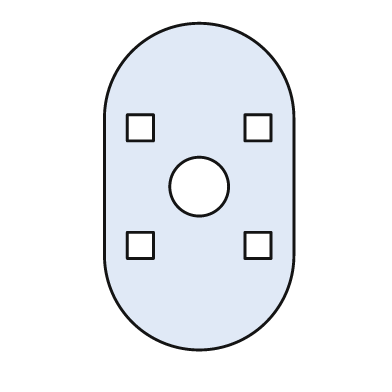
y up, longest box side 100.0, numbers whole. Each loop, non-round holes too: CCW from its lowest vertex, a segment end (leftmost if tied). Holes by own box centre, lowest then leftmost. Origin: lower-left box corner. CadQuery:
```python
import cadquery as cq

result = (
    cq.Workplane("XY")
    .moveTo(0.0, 29.0)
    .threePointArc((29.0, 0.0), (58.0, 29.0))
    .lineTo(58.0, 71.0)
    .threePointArc((29.0, 100.0), (0.0, 71.0))
    .close()
    .moveTo(7.0, 28.0)
    .lineTo(15.0, 28.0)
    .lineTo(15.0, 36.0)
    .lineTo(7.0, 36.0)
    .close()
    .moveTo(43.0, 28.0)
    .lineTo(51.0, 28.0)
    .lineTo(51.0, 36.0)
    .lineTo(43.0, 36.0)
    .close()
    .moveTo(29.0, 50.0)
    .circle(9.0)
    .moveTo(7.0, 64.0)
    .lineTo(15.0, 64.0)
    .lineTo(15.0, 72.0)
    .lineTo(7.0, 72.0)
    .close()
    .moveTo(43.0, 64.0)
    .lineTo(51.0, 64.0)
    .lineTo(51.0, 72.0)
    .lineTo(43.0, 72.0)
    .close()
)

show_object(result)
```